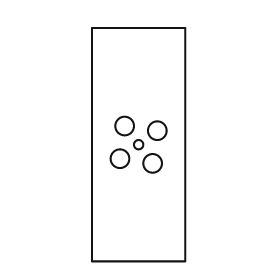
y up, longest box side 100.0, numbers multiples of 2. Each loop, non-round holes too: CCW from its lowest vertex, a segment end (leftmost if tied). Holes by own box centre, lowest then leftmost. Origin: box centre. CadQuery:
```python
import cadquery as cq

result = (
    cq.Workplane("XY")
    .moveTo(-20.0, -50.0)
    .lineTo(20.0, -50.0)
    .lineTo(20.0, 50.0)
    .lineTo(-20.0, 50.0)
    .close()
    .moveTo(6.0, -8.0)
    .circle(4.0)
    .moveTo(-8.0, -6.0)
    .circle(4.0)
    .moveTo(0.0, 0.0)
    .circle(2.0)
    .moveTo(8.0, 6.0)
    .circle(4.0)
    .moveTo(-6.0, 8.0)
    .circle(4.0)
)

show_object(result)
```